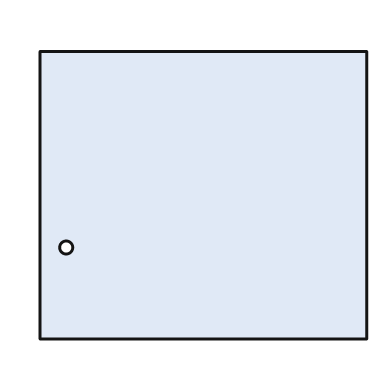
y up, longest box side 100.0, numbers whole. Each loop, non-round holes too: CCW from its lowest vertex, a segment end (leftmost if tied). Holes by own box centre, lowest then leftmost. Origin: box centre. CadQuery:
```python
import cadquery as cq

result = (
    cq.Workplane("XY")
    .moveTo(-50.0, -44.0)
    .lineTo(50.0, -44.0)
    .lineTo(50.0, 44.0)
    .lineTo(-50.0, 44.0)
    .close()
    .moveTo(-42.0, -16.0)
    .circle(2.0)
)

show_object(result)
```